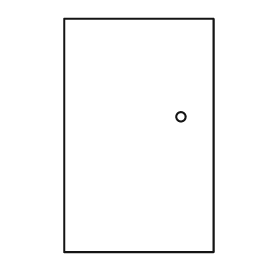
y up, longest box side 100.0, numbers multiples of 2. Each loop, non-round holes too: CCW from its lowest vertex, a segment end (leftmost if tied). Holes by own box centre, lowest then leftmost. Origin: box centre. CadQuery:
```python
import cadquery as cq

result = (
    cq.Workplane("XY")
    .moveTo(-32.0, -50.0)
    .lineTo(32.0, -50.0)
    .lineTo(32.0, 50.0)
    .lineTo(-32.0, 50.0)
    .close()
    .moveTo(18.0, 8.0)
    .circle(2.0)
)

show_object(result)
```